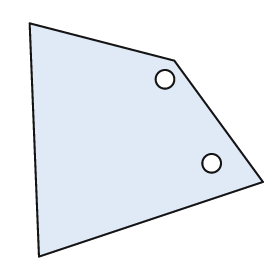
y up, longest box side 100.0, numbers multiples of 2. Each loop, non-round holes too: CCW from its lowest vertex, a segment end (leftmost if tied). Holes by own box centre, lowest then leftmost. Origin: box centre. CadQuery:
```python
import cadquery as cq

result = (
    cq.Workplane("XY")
    .moveTo(-46.0, -50.0)
    .lineTo(50.0, -18.0)
    .lineTo(12.0, 34.0)
    .lineTo(-50.0, 50.0)
    .close()
    .moveTo(28.0, -10.0)
    .circle(4.0)
    .moveTo(8.0, 26.0)
    .circle(4.0)
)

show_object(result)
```